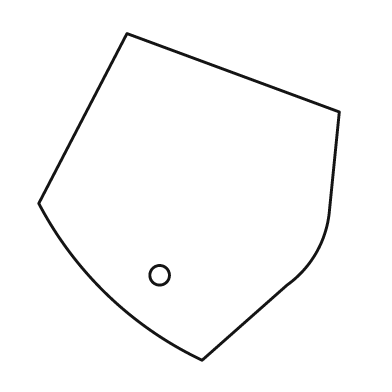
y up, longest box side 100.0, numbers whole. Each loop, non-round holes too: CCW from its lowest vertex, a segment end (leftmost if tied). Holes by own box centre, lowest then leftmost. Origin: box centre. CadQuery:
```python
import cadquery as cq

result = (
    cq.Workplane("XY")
    .moveTo(4.0, -50.0)
    .lineTo(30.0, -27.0)
    .threePointArc((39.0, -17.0), (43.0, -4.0))
    .lineTo(46.0, 26.0)
    .lineTo(-19.0, 50.0)
    .lineTo(-46.0, -2.0)
    .threePointArc((-25.0, -30.0), (4.0, -50.0))
    .close()
    .moveTo(-9.0, -24.0)
    .circle(3.0)
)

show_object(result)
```